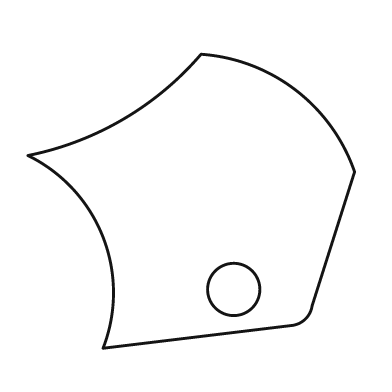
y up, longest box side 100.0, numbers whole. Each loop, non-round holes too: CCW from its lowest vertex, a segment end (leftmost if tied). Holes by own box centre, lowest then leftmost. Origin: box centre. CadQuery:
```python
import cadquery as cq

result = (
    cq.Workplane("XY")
    .moveTo(-27.0, -45.0)
    .lineTo(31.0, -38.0)
    .threePointArc((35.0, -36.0), (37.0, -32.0))
    .lineTo(50.0, 9.0)
    .threePointArc((32.0, 34.0), (3.0, 45.0))
    .threePointArc((-21.0, 25.0), (-50.0, 14.0))
    .threePointArc((-27.0, -11.0), (-27.0, -45.0))
    .close()
    .moveTo(13.0, -27.0)
    .circle(8.0)
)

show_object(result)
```